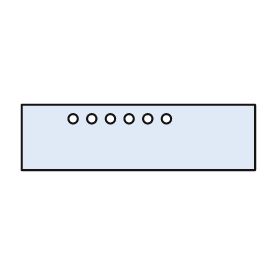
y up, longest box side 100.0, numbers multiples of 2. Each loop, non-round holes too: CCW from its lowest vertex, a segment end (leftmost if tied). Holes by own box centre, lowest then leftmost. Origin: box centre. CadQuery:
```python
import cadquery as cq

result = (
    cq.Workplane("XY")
    .moveTo(-50.0, -14.0)
    .lineTo(50.0, -14.0)
    .lineTo(50.0, 14.0)
    .lineTo(-50.0, 14.0)
    .close()
    .moveTo(-28.0, 8.0)
    .circle(2.0)
    .moveTo(-20.0, 8.0)
    .circle(2.0)
    .moveTo(-12.0, 8.0)
    .circle(2.0)
    .moveTo(-4.0, 8.0)
    .circle(2.0)
    .moveTo(4.0, 8.0)
    .circle(2.0)
    .moveTo(12.0, 8.0)
    .circle(2.0)
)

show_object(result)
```